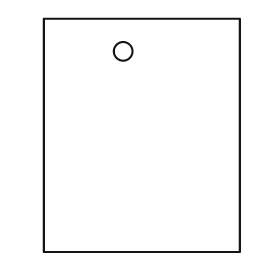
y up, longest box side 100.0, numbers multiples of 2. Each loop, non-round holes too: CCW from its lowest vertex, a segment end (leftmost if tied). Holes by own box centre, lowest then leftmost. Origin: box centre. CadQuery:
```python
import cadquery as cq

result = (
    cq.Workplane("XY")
    .moveTo(-42.0, -50.0)
    .lineTo(42.0, -50.0)
    .lineTo(42.0, 50.0)
    .lineTo(-42.0, 50.0)
    .close()
    .moveTo(-8.0, 36.0)
    .circle(4.0)
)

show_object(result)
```